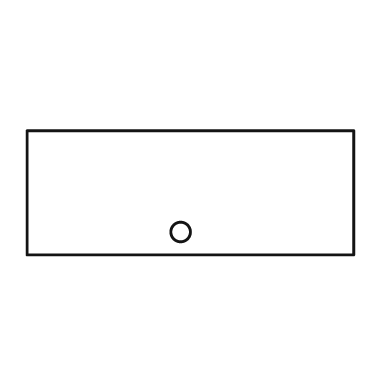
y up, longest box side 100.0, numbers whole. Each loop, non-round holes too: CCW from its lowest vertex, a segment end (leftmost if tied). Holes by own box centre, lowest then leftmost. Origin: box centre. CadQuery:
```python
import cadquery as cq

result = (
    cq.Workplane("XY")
    .moveTo(-50.0, -19.0)
    .lineTo(50.0, -19.0)
    .lineTo(50.0, 19.0)
    .lineTo(-50.0, 19.0)
    .close()
    .moveTo(-3.0, -12.0)
    .circle(3.0)
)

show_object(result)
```